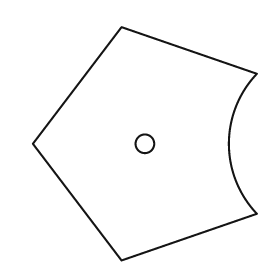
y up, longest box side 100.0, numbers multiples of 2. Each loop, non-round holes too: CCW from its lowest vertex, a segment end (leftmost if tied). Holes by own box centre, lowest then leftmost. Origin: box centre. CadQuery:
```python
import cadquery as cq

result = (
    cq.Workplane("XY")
    .moveTo(-10.0, -50.0)
    .lineTo(48.0, -30.0)
    .threePointArc((36.0, 0.0), (48.0, 30.0))
    .lineTo(-10.0, 50.0)
    .lineTo(-48.0, 0.0)
    .close()
    .moveTo(0.0, 0.0)
    .circle(4.0)
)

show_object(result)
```